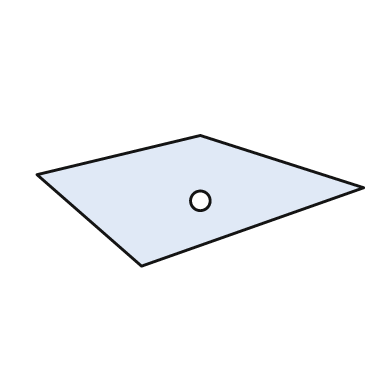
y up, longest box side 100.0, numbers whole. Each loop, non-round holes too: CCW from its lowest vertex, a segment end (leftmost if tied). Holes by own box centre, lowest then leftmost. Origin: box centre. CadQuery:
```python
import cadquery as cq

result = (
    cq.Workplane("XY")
    .moveTo(-18.0, -20.0)
    .lineTo(50.0, 4.0)
    .lineTo(0.0, 20.0)
    .lineTo(-50.0, 8.0)
    .close()
    .moveTo(0.0, 0.0)
    .circle(3.0)
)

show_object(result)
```